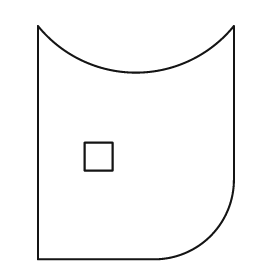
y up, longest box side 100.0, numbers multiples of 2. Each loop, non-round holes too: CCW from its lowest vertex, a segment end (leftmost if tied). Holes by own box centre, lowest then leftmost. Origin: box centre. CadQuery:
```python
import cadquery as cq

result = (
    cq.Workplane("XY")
    .moveTo(-42.0, -50.0)
    .lineTo(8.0, -50.0)
    .threePointArc((32.0, -40.0), (42.0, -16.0))
    .lineTo(42.0, 50.0)
    .threePointArc((0.0, 30.0), (-42.0, 50.0))
    .close()
    .moveTo(-22.0, -12.0)
    .lineTo(-10.0, -12.0)
    .lineTo(-10.0, 0.0)
    .lineTo(-22.0, 0.0)
    .close()
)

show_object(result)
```